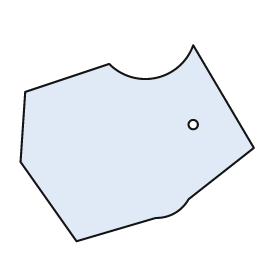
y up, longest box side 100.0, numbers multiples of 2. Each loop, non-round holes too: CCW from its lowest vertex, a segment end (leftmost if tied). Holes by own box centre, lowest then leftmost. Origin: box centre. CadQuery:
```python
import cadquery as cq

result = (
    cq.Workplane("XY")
    .moveTo(-26.0, -42.0)
    .lineTo(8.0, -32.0)
    .threePointArc((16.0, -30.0), (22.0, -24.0))
    .lineTo(50.0, -2.0)
    .lineTo(24.0, 42.0)
    .threePointArc((8.0, 28.0), (-12.0, 34.0))
    .lineTo(-48.0, 22.0)
    .lineTo(-50.0, -8.0)
    .close()
    .moveTo(24.0, 8.0)
    .circle(2.0)
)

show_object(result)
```